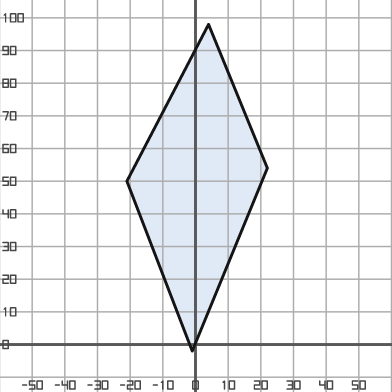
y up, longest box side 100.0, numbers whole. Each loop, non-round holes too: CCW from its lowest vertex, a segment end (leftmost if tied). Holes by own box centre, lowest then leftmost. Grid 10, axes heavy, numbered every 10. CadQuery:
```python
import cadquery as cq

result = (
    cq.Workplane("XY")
    .moveTo(-1.0, -2.0)
    .lineTo(22.0, 54.0)
    .lineTo(4.0, 98.0)
    .lineTo(-21.0, 50.0)
    .close()
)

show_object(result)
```